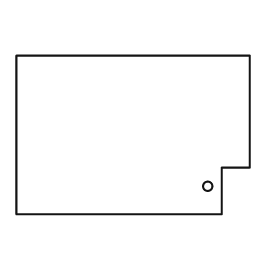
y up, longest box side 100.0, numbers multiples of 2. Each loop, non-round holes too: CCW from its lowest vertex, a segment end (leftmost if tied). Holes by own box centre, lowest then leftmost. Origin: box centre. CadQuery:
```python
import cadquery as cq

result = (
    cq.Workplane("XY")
    .moveTo(-50.0, -34.0)
    .lineTo(38.0, -34.0)
    .lineTo(38.0, -14.0)
    .lineTo(50.0, -14.0)
    .lineTo(50.0, 34.0)
    .lineTo(-50.0, 34.0)
    .close()
    .moveTo(32.0, -22.0)
    .circle(2.0)
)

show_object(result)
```